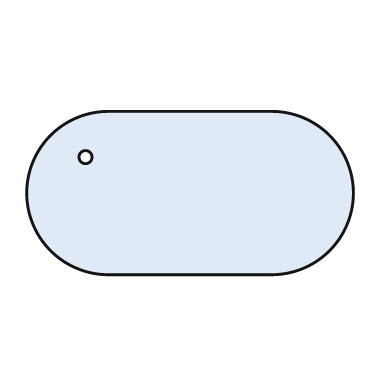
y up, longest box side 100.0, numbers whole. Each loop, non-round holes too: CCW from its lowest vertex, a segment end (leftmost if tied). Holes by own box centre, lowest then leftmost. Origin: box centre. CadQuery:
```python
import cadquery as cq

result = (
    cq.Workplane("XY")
    .moveTo(-25.0, -25.0)
    .lineTo(25.0, -25.0)
    .threePointArc((50.0, 0.0), (25.0, 25.0))
    .lineTo(-25.0, 25.0)
    .threePointArc((-50.0, 0.0), (-25.0, -25.0))
    .close()
    .moveTo(-32.0, 11.0)
    .circle(2.0)
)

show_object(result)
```